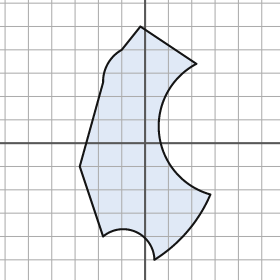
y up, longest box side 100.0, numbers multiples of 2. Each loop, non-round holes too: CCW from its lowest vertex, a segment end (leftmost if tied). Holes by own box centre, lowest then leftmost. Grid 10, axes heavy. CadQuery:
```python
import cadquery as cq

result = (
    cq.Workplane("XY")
    .moveTo(4.0, -50.0)
    .threePointArc((18.0, -38.0), (28.0, -22.0))
    .threePointArc((6.0, 4.0), (22.0, 34.0))
    .lineTo(-2.0, 50.0)
    .lineTo(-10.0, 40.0)
    .threePointArc((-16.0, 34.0), (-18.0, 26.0))
    .lineTo(-28.0, -10.0)
    .lineTo(-18.0, -40.0)
    .threePointArc((-4.0, -38.0), (4.0, -50.0))
    .close()
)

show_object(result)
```